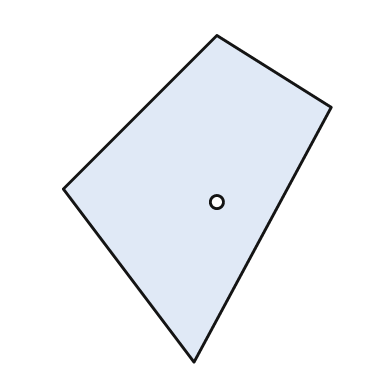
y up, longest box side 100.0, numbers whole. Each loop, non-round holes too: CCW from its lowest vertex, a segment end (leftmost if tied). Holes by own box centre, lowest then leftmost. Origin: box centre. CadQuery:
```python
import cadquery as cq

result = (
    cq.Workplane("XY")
    .moveTo(-1.0, -50.0)
    .lineTo(41.0, 28.0)
    .lineTo(6.0, 50.0)
    .lineTo(-41.0, 3.0)
    .close()
    .moveTo(6.0, -1.0)
    .circle(2.0)
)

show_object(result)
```